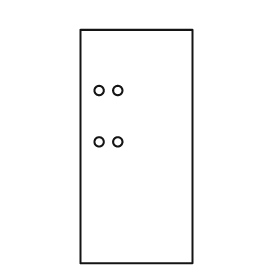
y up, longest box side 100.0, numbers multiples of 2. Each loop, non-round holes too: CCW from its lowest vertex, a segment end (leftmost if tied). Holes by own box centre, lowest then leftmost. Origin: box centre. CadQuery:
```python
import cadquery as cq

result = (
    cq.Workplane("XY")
    .moveTo(-24.0, -50.0)
    .lineTo(24.0, -50.0)
    .lineTo(24.0, 50.0)
    .lineTo(-24.0, 50.0)
    .close()
    .moveTo(-16.0, 2.0)
    .circle(2.0)
    .moveTo(-8.0, 2.0)
    .circle(2.0)
    .moveTo(-16.0, 24.0)
    .circle(2.0)
    .moveTo(-8.0, 24.0)
    .circle(2.0)
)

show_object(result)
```